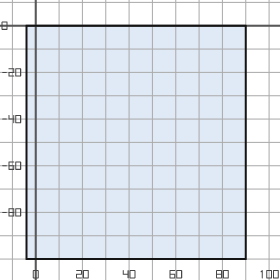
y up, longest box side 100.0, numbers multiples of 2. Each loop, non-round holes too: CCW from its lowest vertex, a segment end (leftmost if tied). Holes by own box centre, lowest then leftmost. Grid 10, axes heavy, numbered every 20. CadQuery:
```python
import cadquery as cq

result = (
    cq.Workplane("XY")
    .moveTo(-4.0, -100.0)
    .lineTo(90.0, -100.0)
    .lineTo(90.0, 0.0)
    .lineTo(-4.0, 0.0)
    .close()
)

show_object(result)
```